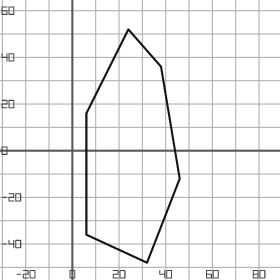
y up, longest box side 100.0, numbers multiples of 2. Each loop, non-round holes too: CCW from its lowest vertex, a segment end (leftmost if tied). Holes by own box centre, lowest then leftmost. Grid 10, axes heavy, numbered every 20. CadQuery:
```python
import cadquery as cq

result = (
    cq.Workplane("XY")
    .moveTo(32.0, -48.0)
    .lineTo(46.0, -12.0)
    .lineTo(38.0, 36.0)
    .lineTo(24.0, 52.0)
    .lineTo(6.0, 16.0)
    .lineTo(6.0, -36.0)
    .close()
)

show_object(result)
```